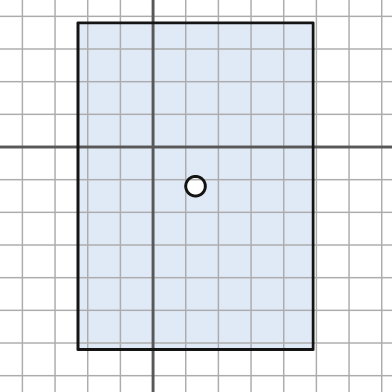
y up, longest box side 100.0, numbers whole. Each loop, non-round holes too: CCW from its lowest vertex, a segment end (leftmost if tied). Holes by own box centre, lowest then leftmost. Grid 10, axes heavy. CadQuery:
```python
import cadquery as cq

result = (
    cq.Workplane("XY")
    .moveTo(-23.0, -62.0)
    .lineTo(49.0, -62.0)
    .lineTo(49.0, 38.0)
    .lineTo(-23.0, 38.0)
    .close()
    .moveTo(13.0, -12.0)
    .circle(3.0)
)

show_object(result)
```